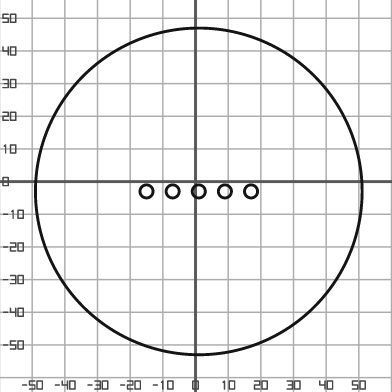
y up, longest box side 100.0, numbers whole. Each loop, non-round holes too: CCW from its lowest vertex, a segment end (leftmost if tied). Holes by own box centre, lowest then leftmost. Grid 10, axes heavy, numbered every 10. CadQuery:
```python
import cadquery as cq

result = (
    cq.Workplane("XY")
    .moveTo(1.0, -3.0)
    .circle(50.0)
    .moveTo(-15.0, -3.0)
    .circle(2.0)
    .moveTo(-7.0, -3.0)
    .circle(2.0)
    .moveTo(1.0, -3.0)
    .circle(2.0)
    .moveTo(9.0, -3.0)
    .circle(2.0)
    .moveTo(17.0, -3.0)
    .circle(2.0)
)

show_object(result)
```